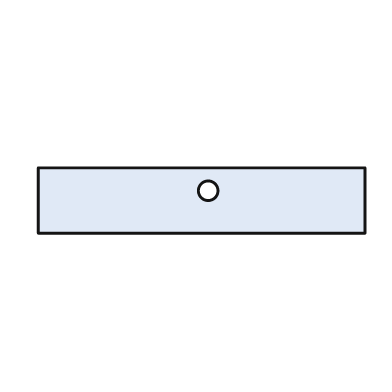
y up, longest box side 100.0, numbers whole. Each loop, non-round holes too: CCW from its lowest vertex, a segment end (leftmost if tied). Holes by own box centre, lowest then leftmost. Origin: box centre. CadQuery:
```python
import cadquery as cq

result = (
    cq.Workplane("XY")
    .moveTo(-50.0, -10.0)
    .lineTo(50.0, -10.0)
    .lineTo(50.0, 10.0)
    .lineTo(-50.0, 10.0)
    .close()
    .moveTo(2.0, 3.0)
    .circle(3.0)
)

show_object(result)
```